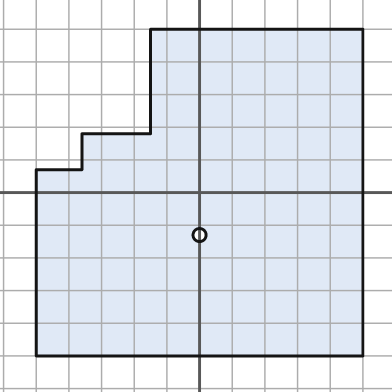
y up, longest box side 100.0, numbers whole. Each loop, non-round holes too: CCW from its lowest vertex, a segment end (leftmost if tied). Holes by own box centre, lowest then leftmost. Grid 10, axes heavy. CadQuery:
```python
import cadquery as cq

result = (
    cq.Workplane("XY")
    .moveTo(-50.0, -50.0)
    .lineTo(50.0, -50.0)
    .lineTo(50.0, 50.0)
    .lineTo(-15.0, 50.0)
    .lineTo(-15.0, 18.0)
    .lineTo(-36.0, 18.0)
    .lineTo(-36.0, 7.0)
    .lineTo(-50.0, 7.0)
    .close()
    .moveTo(0.0, -13.0)
    .circle(2.0)
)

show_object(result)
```